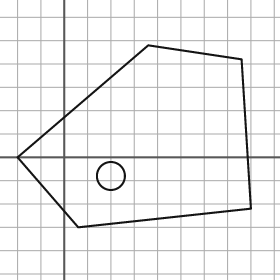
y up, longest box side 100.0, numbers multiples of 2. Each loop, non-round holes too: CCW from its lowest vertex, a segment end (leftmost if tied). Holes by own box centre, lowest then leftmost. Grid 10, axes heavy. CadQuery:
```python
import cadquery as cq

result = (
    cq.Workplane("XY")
    .moveTo(6.0, -30.0)
    .lineTo(80.0, -22.0)
    .lineTo(76.0, 42.0)
    .lineTo(36.0, 48.0)
    .lineTo(-20.0, 0.0)
    .close()
    .moveTo(20.0, -8.0)
    .circle(6.0)
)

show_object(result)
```